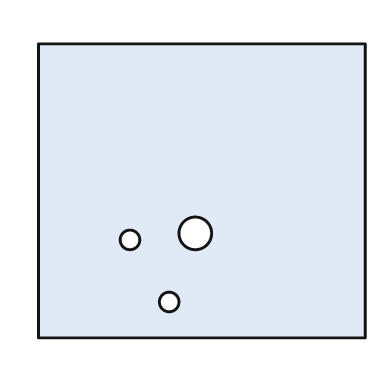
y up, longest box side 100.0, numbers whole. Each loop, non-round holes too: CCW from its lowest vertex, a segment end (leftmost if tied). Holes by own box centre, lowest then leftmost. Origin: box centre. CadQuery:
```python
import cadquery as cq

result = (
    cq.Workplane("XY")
    .moveTo(-50.0, -45.0)
    .lineTo(50.0, -45.0)
    .lineTo(50.0, 45.0)
    .lineTo(-50.0, 45.0)
    .close()
    .moveTo(-10.0, -34.0)
    .circle(3.0)
    .moveTo(-22.0, -15.0)
    .circle(3.0)
    .moveTo(-2.0, -13.0)
    .circle(5.0)
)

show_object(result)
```